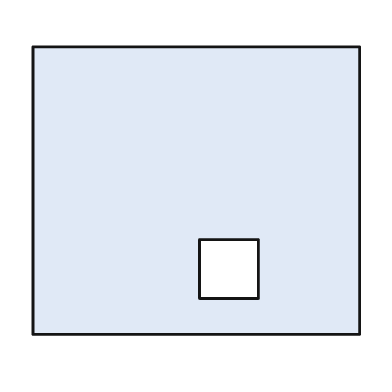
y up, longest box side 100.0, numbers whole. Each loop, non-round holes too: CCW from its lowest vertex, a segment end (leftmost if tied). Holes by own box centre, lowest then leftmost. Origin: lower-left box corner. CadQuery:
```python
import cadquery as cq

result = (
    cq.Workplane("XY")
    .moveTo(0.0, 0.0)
    .lineTo(100.0, 0.0)
    .lineTo(100.0, 88.0)
    .lineTo(0.0, 88.0)
    .close()
    .moveTo(51.0, 11.0)
    .lineTo(69.0, 11.0)
    .lineTo(69.0, 29.0)
    .lineTo(51.0, 29.0)
    .close()
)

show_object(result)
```